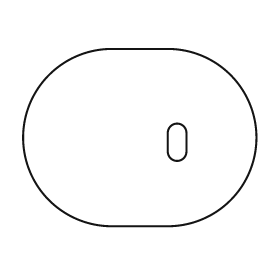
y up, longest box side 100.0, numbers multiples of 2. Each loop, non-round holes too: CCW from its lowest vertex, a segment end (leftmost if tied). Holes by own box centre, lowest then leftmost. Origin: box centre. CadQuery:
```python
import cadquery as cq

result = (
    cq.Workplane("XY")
    .moveTo(-12.0, -38.0)
    .lineTo(12.0, -38.0)
    .threePointArc((50.0, 0.0), (12.0, 38.0))
    .lineTo(-12.0, 38.0)
    .threePointArc((-50.0, 0.0), (-12.0, -38.0))
    .close()
    .moveTo(12.0, -6.0)
    .threePointArc((16.0, -10.0), (20.0, -6.0))
    .lineTo(20.0, 2.0)
    .threePointArc((16.0, 6.0), (12.0, 2.0))
    .close()
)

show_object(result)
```